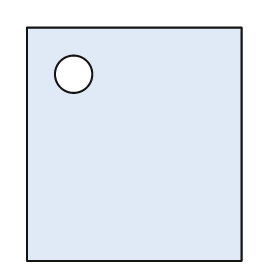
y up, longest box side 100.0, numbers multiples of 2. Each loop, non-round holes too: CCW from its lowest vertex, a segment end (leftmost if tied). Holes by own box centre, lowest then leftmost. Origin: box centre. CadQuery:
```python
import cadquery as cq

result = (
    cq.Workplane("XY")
    .moveTo(-46.0, -50.0)
    .lineTo(46.0, -50.0)
    .lineTo(46.0, 50.0)
    .lineTo(-46.0, 50.0)
    .close()
    .moveTo(-26.0, 30.0)
    .circle(8.0)
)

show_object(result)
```